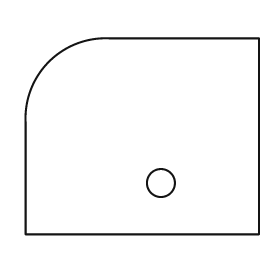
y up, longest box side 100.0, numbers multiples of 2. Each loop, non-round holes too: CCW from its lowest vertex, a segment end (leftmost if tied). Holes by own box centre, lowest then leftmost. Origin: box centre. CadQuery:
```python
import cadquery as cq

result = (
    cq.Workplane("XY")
    .moveTo(-50.0, -42.0)
    .lineTo(50.0, -42.0)
    .lineTo(50.0, 42.0)
    .lineTo(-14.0, 42.0)
    .threePointArc((-40.0, 32.0), (-50.0, 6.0))
    .close()
    .moveTo(8.0, -20.0)
    .circle(6.0)
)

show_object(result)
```